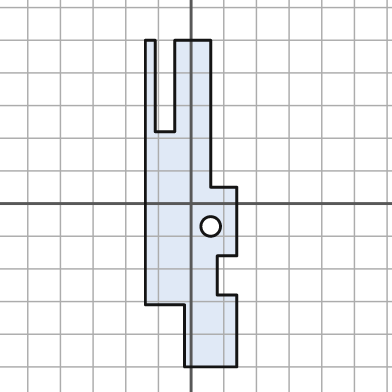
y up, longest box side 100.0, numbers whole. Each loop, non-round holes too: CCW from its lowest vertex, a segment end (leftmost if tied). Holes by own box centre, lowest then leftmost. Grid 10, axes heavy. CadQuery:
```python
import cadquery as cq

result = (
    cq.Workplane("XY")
    .moveTo(-2.0, -50.0)
    .lineTo(14.0, -50.0)
    .lineTo(14.0, -28.0)
    .lineTo(8.0, -28.0)
    .lineTo(8.0, -16.0)
    .lineTo(14.0, -16.0)
    .lineTo(14.0, 5.0)
    .lineTo(6.0, 5.0)
    .lineTo(6.0, 50.0)
    .lineTo(-5.0, 50.0)
    .lineTo(-5.0, 22.0)
    .lineTo(-11.0, 22.0)
    .lineTo(-11.0, 50.0)
    .lineTo(-14.0, 50.0)
    .lineTo(-14.0, -31.0)
    .lineTo(-2.0, -31.0)
    .close()
    .moveTo(6.0, -7.0)
    .circle(3.0)
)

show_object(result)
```